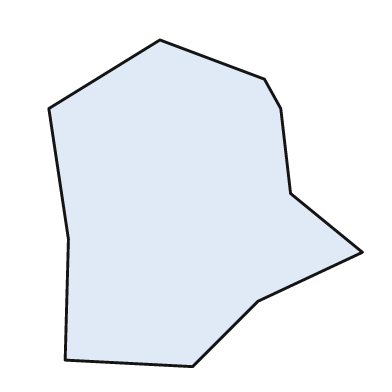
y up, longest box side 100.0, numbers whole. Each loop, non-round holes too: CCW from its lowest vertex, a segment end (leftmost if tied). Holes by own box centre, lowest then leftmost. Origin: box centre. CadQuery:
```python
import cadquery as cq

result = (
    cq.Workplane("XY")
    .moveTo(-4.0, -50.0)
    .lineTo(16.0, -30.0)
    .lineTo(48.0, -15.0)
    .lineTo(26.0, 3.0)
    .lineTo(23.0, 29.0)
    .lineTo(18.0, 38.0)
    .lineTo(-14.0, 50.0)
    .lineTo(-48.0, 29.0)
    .lineTo(-42.0, -11.0)
    .lineTo(-43.0, -48.0)
    .close()
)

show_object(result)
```